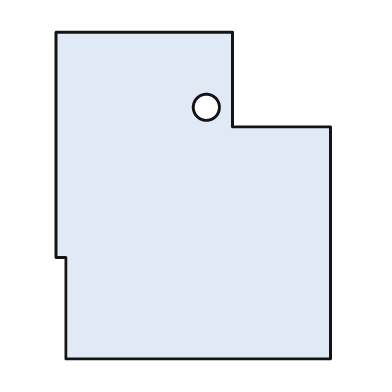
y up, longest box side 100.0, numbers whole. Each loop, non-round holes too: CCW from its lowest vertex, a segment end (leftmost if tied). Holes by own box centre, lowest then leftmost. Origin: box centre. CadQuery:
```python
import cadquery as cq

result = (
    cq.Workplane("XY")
    .moveTo(-39.0, -50.0)
    .lineTo(42.0, -50.0)
    .lineTo(42.0, 21.0)
    .lineTo(12.0, 21.0)
    .lineTo(12.0, 50.0)
    .lineTo(-42.0, 50.0)
    .lineTo(-42.0, -19.0)
    .lineTo(-39.0, -19.0)
    .close()
    .moveTo(4.0, 27.0)
    .circle(4.0)
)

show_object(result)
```